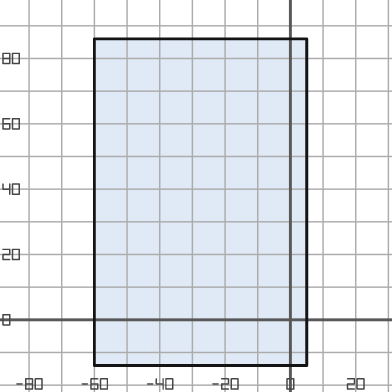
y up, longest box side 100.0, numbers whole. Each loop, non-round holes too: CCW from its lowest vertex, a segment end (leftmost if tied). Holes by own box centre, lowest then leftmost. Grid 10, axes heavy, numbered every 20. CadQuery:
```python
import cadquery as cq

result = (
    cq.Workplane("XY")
    .moveTo(-60.0, -14.0)
    .lineTo(5.0, -14.0)
    .lineTo(5.0, 86.0)
    .lineTo(-60.0, 86.0)
    .close()
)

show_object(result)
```